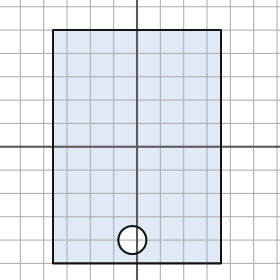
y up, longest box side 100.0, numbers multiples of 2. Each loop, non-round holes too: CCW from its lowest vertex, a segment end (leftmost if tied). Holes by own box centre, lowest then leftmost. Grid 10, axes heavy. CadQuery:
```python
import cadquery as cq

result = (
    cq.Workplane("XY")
    .moveTo(-36.0, -50.0)
    .lineTo(36.0, -50.0)
    .lineTo(36.0, 50.0)
    .lineTo(-36.0, 50.0)
    .close()
    .moveTo(-2.0, -40.0)
    .circle(6.0)
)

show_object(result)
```